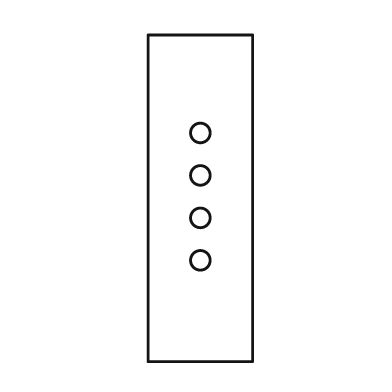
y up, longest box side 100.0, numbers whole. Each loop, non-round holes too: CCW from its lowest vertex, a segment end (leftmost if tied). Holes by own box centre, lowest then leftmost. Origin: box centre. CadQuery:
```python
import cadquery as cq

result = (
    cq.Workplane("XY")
    .moveTo(-16.0, -50.0)
    .lineTo(16.0, -50.0)
    .lineTo(16.0, 50.0)
    .lineTo(-16.0, 50.0)
    .close()
    .moveTo(0.0, -19.0)
    .circle(3.0)
    .moveTo(0.0, -6.0)
    .circle(3.0)
    .moveTo(0.0, 7.0)
    .circle(3.0)
    .moveTo(0.0, 20.0)
    .circle(3.0)
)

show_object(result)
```